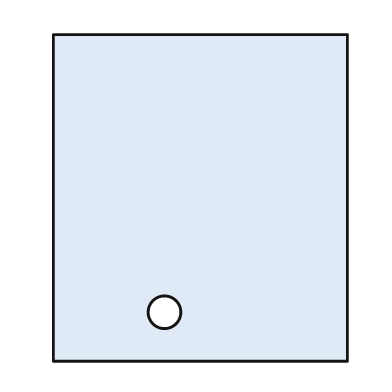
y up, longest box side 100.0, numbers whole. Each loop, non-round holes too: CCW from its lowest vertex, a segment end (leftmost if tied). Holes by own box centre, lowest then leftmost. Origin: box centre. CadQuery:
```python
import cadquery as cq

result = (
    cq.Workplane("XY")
    .moveTo(-45.0, -50.0)
    .lineTo(45.0, -50.0)
    .lineTo(45.0, 50.0)
    .lineTo(-45.0, 50.0)
    .close()
    .moveTo(-11.0, -35.0)
    .circle(5.0)
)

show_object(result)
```